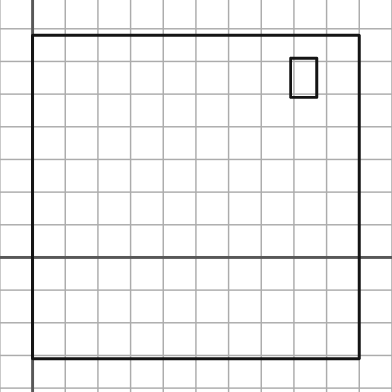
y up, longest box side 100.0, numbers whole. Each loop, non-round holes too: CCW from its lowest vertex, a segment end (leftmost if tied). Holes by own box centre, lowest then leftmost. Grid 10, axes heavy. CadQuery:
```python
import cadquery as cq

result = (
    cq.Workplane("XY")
    .moveTo(0.0, -31.0)
    .lineTo(100.0, -31.0)
    .lineTo(100.0, 68.0)
    .lineTo(0.0, 68.0)
    .close()
    .moveTo(79.0, 49.0)
    .lineTo(87.0, 49.0)
    .lineTo(87.0, 61.0)
    .lineTo(79.0, 61.0)
    .close()
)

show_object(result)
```